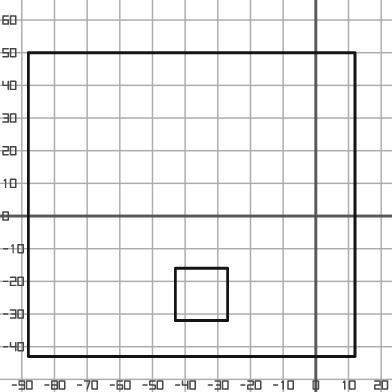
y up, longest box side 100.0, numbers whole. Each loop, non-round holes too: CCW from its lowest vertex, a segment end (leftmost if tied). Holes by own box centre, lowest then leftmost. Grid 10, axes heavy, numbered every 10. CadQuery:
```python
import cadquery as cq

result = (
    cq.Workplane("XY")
    .moveTo(-88.0, -43.0)
    .lineTo(12.0, -43.0)
    .lineTo(12.0, 50.0)
    .lineTo(-88.0, 50.0)
    .close()
    .moveTo(-43.0, -32.0)
    .lineTo(-27.0, -32.0)
    .lineTo(-27.0, -16.0)
    .lineTo(-43.0, -16.0)
    .close()
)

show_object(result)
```